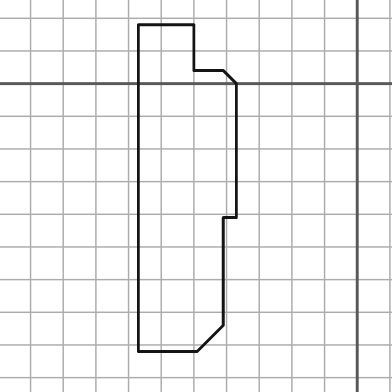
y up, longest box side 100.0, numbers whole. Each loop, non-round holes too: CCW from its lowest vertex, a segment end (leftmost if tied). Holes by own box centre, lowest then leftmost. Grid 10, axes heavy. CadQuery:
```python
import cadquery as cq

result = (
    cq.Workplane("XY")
    .moveTo(-67.0, -82.0)
    .lineTo(-49.0, -82.0)
    .lineTo(-41.0, -74.0)
    .lineTo(-41.0, -41.0)
    .lineTo(-37.0, -41.0)
    .lineTo(-37.0, 0.0)
    .lineTo(-41.0, 4.0)
    .lineTo(-50.0, 4.0)
    .lineTo(-50.0, 18.0)
    .lineTo(-67.0, 18.0)
    .close()
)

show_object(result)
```